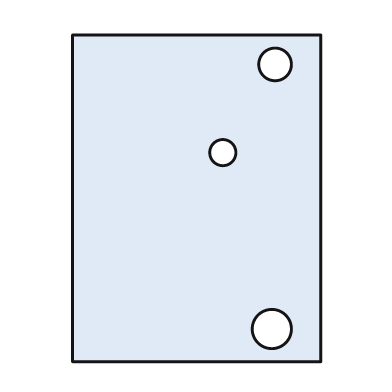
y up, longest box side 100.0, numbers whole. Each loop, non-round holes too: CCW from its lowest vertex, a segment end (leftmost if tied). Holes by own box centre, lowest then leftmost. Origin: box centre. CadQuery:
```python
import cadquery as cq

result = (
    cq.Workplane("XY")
    .moveTo(-38.0, -50.0)
    .lineTo(38.0, -50.0)
    .lineTo(38.0, 50.0)
    .lineTo(-38.0, 50.0)
    .close()
    .moveTo(23.0, -40.0)
    .circle(6.0)
    .moveTo(8.0, 14.0)
    .circle(4.0)
    .moveTo(24.0, 41.0)
    .circle(5.0)
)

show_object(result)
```